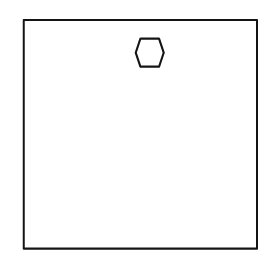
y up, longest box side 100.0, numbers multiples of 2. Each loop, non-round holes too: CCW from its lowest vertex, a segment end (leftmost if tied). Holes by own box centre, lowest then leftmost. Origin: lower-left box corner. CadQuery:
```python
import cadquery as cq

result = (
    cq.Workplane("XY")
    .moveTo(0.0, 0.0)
    .lineTo(100.0, 0.0)
    .lineTo(100.0, 98.0)
    .lineTo(0.0, 98.0)
    .close()
    .moveTo(50.0, 78.0)
    .lineTo(58.0, 78.0)
    .lineTo(60.0, 84.0)
    .lineTo(58.0, 90.0)
    .lineTo(50.0, 90.0)
    .lineTo(48.0, 84.0)
    .close()
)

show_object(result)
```